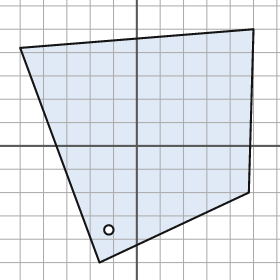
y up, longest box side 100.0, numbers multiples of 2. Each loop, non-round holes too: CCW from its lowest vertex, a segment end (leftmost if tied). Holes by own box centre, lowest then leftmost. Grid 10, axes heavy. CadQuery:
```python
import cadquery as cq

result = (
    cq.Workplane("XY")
    .moveTo(-16.0, -50.0)
    .lineTo(48.0, -20.0)
    .lineTo(50.0, 50.0)
    .lineTo(-50.0, 42.0)
    .close()
    .moveTo(-12.0, -36.0)
    .circle(2.0)
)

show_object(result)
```